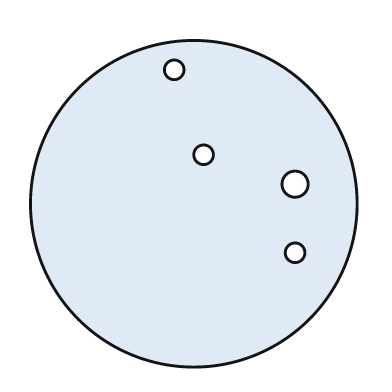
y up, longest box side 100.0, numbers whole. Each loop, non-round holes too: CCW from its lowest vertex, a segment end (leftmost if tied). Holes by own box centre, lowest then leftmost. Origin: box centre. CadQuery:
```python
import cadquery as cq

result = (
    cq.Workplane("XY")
    .moveTo(0.0, 0.0)
    .circle(50.0)
    .moveTo(31.0, -15.0)
    .circle(3.0)
    .moveTo(31.0, 6.0)
    .circle(4.0)
    .moveTo(3.0, 15.0)
    .circle(3.0)
    .moveTo(-6.0, 41.0)
    .circle(3.0)
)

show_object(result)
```